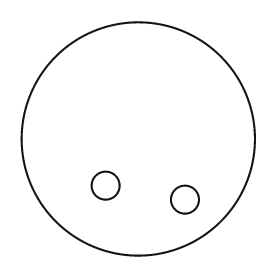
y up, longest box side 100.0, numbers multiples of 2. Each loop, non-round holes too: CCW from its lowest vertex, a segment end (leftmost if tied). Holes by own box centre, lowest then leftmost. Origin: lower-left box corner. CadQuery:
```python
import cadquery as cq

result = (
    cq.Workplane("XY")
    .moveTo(50.0, 50.0)
    .circle(50.0)
    .moveTo(70.0, 24.0)
    .circle(6.0)
    .moveTo(36.0, 30.0)
    .circle(6.0)
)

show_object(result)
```